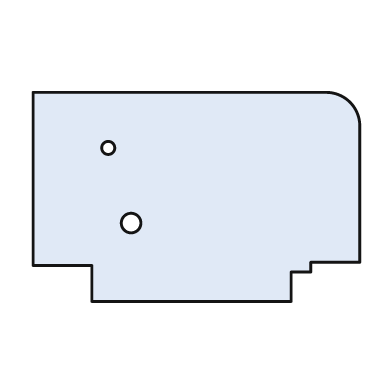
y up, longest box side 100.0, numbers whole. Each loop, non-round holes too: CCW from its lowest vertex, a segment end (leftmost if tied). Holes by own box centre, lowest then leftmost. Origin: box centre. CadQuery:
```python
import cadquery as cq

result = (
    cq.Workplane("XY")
    .moveTo(-32.0, -32.0)
    .lineTo(29.0, -32.0)
    .lineTo(29.0, -23.0)
    .lineTo(35.0, -23.0)
    .lineTo(35.0, -20.0)
    .lineTo(50.0, -20.0)
    .lineTo(50.0, 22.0)
    .threePointArc((47.0, 29.0), (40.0, 32.0))
    .lineTo(-50.0, 32.0)
    .lineTo(-50.0, -21.0)
    .lineTo(-32.0, -21.0)
    .close()
    .moveTo(-20.0, -8.0)
    .circle(3.0)
    .moveTo(-27.0, 15.0)
    .circle(2.0)
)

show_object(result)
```